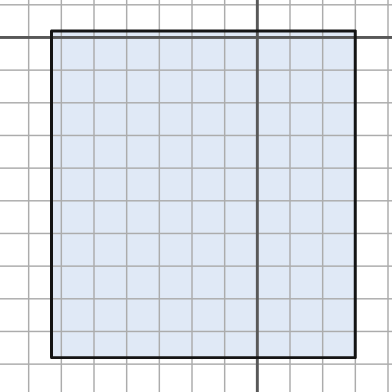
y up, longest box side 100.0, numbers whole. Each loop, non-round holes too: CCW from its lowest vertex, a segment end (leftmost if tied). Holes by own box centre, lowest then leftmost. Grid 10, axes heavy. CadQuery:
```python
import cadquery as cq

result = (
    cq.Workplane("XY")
    .moveTo(-63.0, -98.0)
    .lineTo(30.0, -98.0)
    .lineTo(30.0, 2.0)
    .lineTo(-63.0, 2.0)
    .close()
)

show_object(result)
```